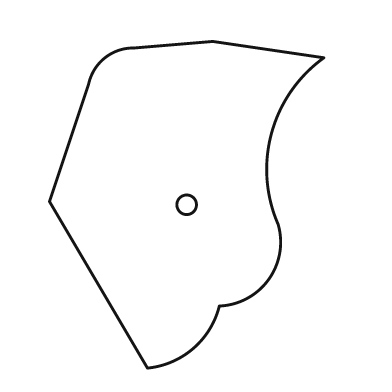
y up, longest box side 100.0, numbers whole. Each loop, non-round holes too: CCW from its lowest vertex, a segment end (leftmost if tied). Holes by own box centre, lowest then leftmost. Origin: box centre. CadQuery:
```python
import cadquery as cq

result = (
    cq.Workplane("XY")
    .moveTo(-12.0, -50.0)
    .threePointArc((2.0, -44.0), (10.0, -31.0))
    .threePointArc((25.0, -23.0), (28.0, -6.0))
    .threePointArc((26.0, 22.0), (42.0, 45.0))
    .lineTo(8.0, 50.0)
    .lineTo(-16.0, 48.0)
    .threePointArc((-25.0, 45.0), (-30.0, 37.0))
    .lineTo(-42.0, 1.0)
    .close()
    .moveTo(0.0, 0.0)
    .circle(3.0)
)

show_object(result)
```